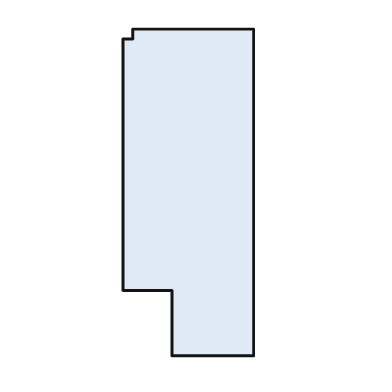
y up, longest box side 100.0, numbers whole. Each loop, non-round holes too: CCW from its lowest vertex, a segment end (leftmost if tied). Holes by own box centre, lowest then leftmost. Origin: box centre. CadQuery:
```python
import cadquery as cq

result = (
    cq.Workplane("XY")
    .moveTo(-5.0, -50.0)
    .lineTo(20.0, -50.0)
    .lineTo(20.0, 50.0)
    .lineTo(-17.0, 50.0)
    .lineTo(-17.0, 47.0)
    .lineTo(-20.0, 47.0)
    .lineTo(-20.0, -30.0)
    .lineTo(-5.0, -30.0)
    .close()
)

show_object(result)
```